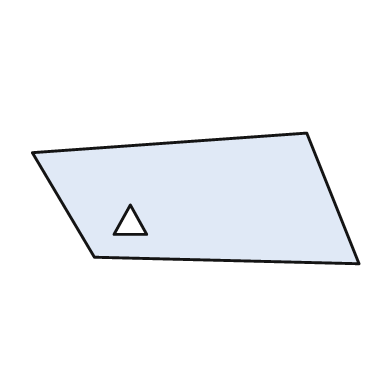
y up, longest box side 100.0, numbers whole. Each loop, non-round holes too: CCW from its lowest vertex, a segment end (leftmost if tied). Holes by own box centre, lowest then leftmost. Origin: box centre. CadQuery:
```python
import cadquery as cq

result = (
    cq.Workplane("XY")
    .moveTo(50.0, -20.0)
    .lineTo(34.0, 20.0)
    .lineTo(-50.0, 14.0)
    .lineTo(-31.0, -18.0)
    .close()
    .moveTo(-25.0, -11.0)
    .lineTo(-15.0, -11.0)
    .lineTo(-20.0, -2.0)
    .close()
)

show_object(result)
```